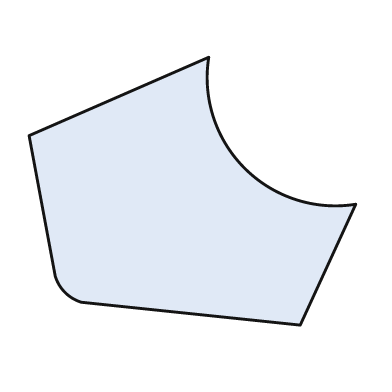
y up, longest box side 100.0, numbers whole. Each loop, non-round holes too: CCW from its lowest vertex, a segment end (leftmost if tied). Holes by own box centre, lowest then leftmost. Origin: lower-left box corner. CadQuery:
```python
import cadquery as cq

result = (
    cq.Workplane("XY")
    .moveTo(83.0, 0.0)
    .lineTo(100.0, 37.0)
    .threePointArc((66.0, 48.0), (55.0, 82.0))
    .lineTo(0.0, 58.0)
    .lineTo(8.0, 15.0)
    .threePointArc((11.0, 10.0), (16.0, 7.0))
    .close()
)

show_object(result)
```